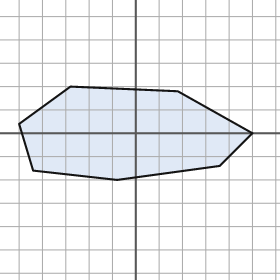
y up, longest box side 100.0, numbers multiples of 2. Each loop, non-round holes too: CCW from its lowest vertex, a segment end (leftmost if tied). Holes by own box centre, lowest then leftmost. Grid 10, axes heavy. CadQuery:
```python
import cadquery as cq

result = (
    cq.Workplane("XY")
    .moveTo(-8.0, -20.0)
    .lineTo(36.0, -14.0)
    .lineTo(50.0, 0.0)
    .lineTo(18.0, 18.0)
    .lineTo(-28.0, 20.0)
    .lineTo(-50.0, 4.0)
    .lineTo(-44.0, -16.0)
    .close()
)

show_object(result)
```